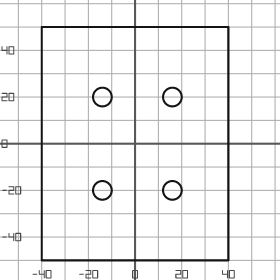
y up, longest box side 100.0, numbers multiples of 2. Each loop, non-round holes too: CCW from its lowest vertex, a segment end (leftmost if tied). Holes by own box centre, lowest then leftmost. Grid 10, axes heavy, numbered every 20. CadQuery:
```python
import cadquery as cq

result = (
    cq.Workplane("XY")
    .moveTo(-40.0, -50.0)
    .lineTo(40.0, -50.0)
    .lineTo(40.0, 50.0)
    .lineTo(-40.0, 50.0)
    .close()
    .moveTo(-14.0, -20.0)
    .circle(4.0)
    .moveTo(16.0, -20.0)
    .circle(4.0)
    .moveTo(-14.0, 20.0)
    .circle(4.0)
    .moveTo(16.0, 20.0)
    .circle(4.0)
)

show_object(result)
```